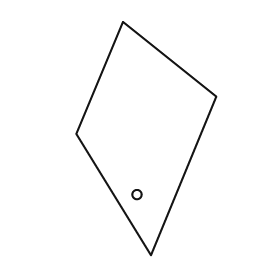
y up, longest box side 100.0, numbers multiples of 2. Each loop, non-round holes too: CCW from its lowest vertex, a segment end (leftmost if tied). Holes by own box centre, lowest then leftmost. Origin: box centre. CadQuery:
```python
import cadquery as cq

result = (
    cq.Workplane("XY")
    .moveTo(2.0, -50.0)
    .lineTo(30.0, 18.0)
    .lineTo(-10.0, 50.0)
    .lineTo(-30.0, 2.0)
    .close()
    .moveTo(-4.0, -24.0)
    .circle(2.0)
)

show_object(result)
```